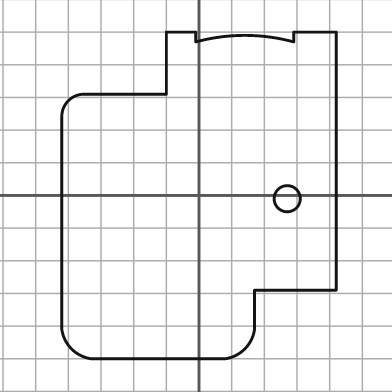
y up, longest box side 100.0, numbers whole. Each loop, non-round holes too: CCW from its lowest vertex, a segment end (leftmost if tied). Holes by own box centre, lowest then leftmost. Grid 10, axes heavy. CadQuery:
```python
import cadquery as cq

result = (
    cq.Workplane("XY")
    .moveTo(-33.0, -50.0)
    .lineTo(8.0, -50.0)
    .threePointArc((14.0, -47.0), (17.0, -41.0))
    .lineTo(17.0, -29.0)
    .lineTo(42.0, -29.0)
    .lineTo(42.0, 50.0)
    .lineTo(29.0, 50.0)
    .lineTo(29.0, 47.0)
    .threePointArc((14.0, 49.0), (-1.0, 47.0))
    .lineTo(-1.0, 50.0)
    .lineTo(-10.0, 50.0)
    .lineTo(-10.0, 31.0)
    .lineTo(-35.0, 31.0)
    .threePointArc((-40.0, 29.0), (-42.0, 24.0))
    .lineTo(-42.0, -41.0)
    .threePointArc((-39.0, -47.0), (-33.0, -50.0))
    .close()
    .moveTo(27.0, -1.0)
    .circle(4.0)
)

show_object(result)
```